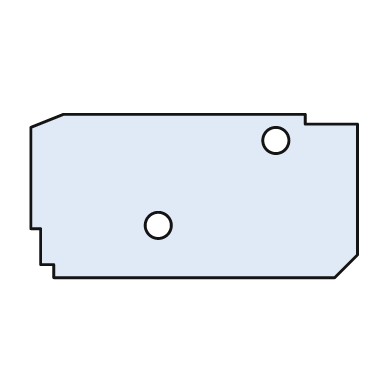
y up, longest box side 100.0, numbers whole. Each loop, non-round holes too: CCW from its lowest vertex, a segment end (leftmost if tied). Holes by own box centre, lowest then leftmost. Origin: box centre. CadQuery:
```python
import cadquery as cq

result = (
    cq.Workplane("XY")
    .moveTo(-43.0, -25.0)
    .lineTo(43.0, -25.0)
    .lineTo(50.0, -18.0)
    .lineTo(50.0, 22.0)
    .lineTo(34.0, 22.0)
    .lineTo(34.0, 25.0)
    .lineTo(-40.0, 25.0)
    .lineTo(-50.0, 21.0)
    .lineTo(-50.0, -10.0)
    .lineTo(-47.0, -10.0)
    .lineTo(-47.0, -21.0)
    .lineTo(-43.0, -21.0)
    .close()
    .moveTo(-11.0, -9.0)
    .circle(4.0)
    .moveTo(25.0, 17.0)
    .circle(4.0)
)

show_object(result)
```